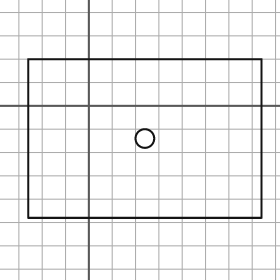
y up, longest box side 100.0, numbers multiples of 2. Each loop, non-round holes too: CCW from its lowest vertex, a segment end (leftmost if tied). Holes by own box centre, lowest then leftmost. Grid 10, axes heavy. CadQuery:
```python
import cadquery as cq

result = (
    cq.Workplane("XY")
    .moveTo(-26.0, -48.0)
    .lineTo(74.0, -48.0)
    .lineTo(74.0, 20.0)
    .lineTo(-26.0, 20.0)
    .close()
    .moveTo(24.0, -14.0)
    .circle(4.0)
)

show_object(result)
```